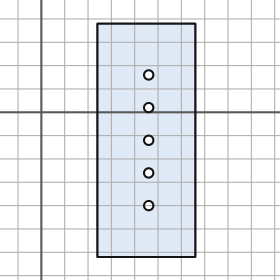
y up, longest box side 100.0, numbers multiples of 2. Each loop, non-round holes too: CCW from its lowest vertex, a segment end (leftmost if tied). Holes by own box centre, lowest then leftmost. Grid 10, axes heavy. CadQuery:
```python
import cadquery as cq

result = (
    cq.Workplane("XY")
    .moveTo(24.0, -62.0)
    .lineTo(66.0, -62.0)
    .lineTo(66.0, 38.0)
    .lineTo(24.0, 38.0)
    .close()
    .moveTo(46.0, -40.0)
    .circle(2.0)
    .moveTo(46.0, -26.0)
    .circle(2.0)
    .moveTo(46.0, -12.0)
    .circle(2.0)
    .moveTo(46.0, 2.0)
    .circle(2.0)
    .moveTo(46.0, 16.0)
    .circle(2.0)
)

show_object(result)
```